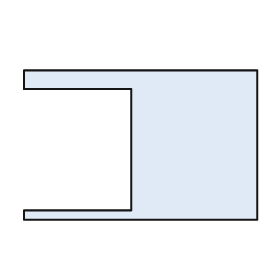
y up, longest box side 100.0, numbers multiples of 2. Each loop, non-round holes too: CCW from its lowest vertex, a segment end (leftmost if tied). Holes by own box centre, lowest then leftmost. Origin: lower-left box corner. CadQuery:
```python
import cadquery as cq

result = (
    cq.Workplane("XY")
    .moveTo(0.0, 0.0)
    .lineTo(100.0, 0.0)
    .lineTo(100.0, 64.0)
    .lineTo(0.0, 64.0)
    .lineTo(0.0, 56.0)
    .lineTo(46.0, 56.0)
    .lineTo(46.0, 4.0)
    .lineTo(0.0, 4.0)
    .close()
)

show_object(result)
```